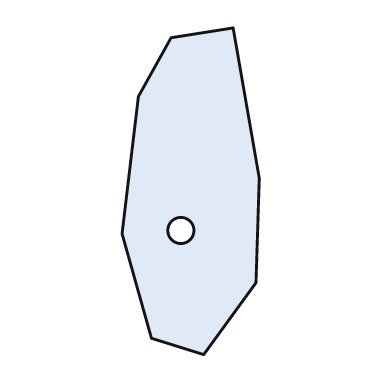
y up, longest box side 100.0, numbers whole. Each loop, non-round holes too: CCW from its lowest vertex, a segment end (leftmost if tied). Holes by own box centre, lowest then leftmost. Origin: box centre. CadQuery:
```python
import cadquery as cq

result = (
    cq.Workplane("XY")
    .moveTo(4.0, -50.0)
    .lineTo(20.0, -28.0)
    .lineTo(21.0, 4.0)
    .lineTo(13.0, 50.0)
    .lineTo(-6.0, 47.0)
    .lineTo(-16.0, 29.0)
    .lineTo(-21.0, -13.0)
    .lineTo(-12.0, -45.0)
    .close()
    .moveTo(-3.0, -12.0)
    .circle(4.0)
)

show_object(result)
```